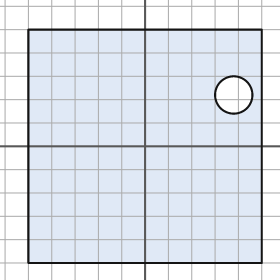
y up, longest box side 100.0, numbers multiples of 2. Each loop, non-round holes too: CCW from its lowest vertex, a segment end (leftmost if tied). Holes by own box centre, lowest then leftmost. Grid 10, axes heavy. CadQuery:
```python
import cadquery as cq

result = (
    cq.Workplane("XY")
    .moveTo(-50.0, -50.0)
    .lineTo(50.0, -50.0)
    .lineTo(50.0, 50.0)
    .lineTo(-50.0, 50.0)
    .close()
    .moveTo(38.0, 22.0)
    .circle(8.0)
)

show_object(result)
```